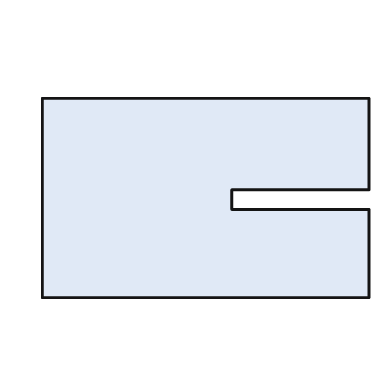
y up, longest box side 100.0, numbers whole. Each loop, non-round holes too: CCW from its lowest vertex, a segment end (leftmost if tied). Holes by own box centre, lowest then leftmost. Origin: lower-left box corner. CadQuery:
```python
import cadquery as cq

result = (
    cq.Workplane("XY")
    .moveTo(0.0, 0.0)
    .lineTo(100.0, 0.0)
    .lineTo(100.0, 27.0)
    .lineTo(58.0, 27.0)
    .lineTo(58.0, 33.0)
    .lineTo(100.0, 33.0)
    .lineTo(100.0, 61.0)
    .lineTo(0.0, 61.0)
    .close()
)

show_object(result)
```